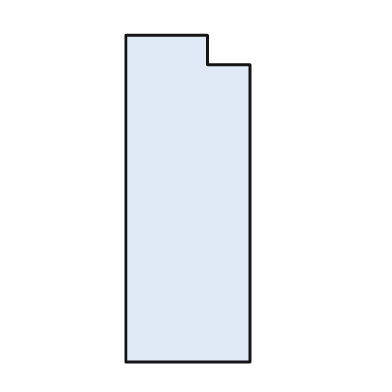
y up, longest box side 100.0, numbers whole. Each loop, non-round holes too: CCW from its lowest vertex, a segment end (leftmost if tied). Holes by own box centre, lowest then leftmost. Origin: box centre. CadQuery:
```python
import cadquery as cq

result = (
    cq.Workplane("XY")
    .moveTo(-19.0, -50.0)
    .lineTo(19.0, -50.0)
    .lineTo(19.0, 41.0)
    .lineTo(6.0, 41.0)
    .lineTo(6.0, 50.0)
    .lineTo(-19.0, 50.0)
    .close()
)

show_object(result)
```